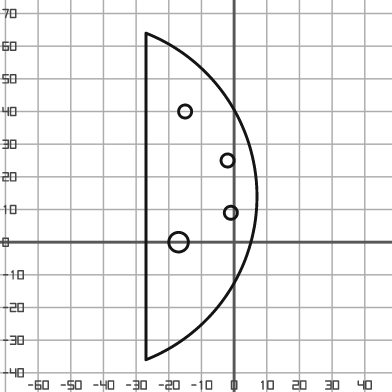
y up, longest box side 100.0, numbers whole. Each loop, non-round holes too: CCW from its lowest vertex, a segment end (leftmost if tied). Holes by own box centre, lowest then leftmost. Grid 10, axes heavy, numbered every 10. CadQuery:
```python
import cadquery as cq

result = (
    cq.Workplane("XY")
    .moveTo(-27.0, -36.0)
    .threePointArc((7.0, 14.0), (-27.0, 64.0))
    .close()
    .moveTo(-17.0, 0.0)
    .circle(3.0)
    .moveTo(-1.0, 9.0)
    .circle(2.0)
    .moveTo(-2.0, 25.0)
    .circle(2.0)
    .moveTo(-15.0, 40.0)
    .circle(2.0)
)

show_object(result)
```